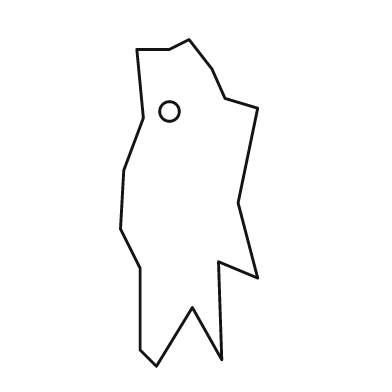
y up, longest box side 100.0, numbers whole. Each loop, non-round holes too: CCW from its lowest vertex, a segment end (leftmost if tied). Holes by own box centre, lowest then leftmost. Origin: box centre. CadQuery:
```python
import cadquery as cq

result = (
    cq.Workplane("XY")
    .moveTo(-10.0, -50.0)
    .lineTo(1.0, -32.0)
    .lineTo(10.0, -48.0)
    .lineTo(9.0, -18.0)
    .lineTo(21.0, -23.0)
    .lineTo(15.0, 0.0)
    .lineTo(21.0, 29.0)
    .lineTo(11.0, 32.0)
    .lineTo(7.0, 41.0)
    .lineTo(0.0, 50.0)
    .lineTo(-6.0, 47.0)
    .lineTo(-16.0, 47.0)
    .lineTo(-14.0, 26.0)
    .lineTo(-20.0, 10.0)
    .lineTo(-21.0, -8.0)
    .lineTo(-15.0, -20.0)
    .lineTo(-15.0, -45.0)
    .close()
    .moveTo(-6.0, 28.0)
    .circle(3.0)
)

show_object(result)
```